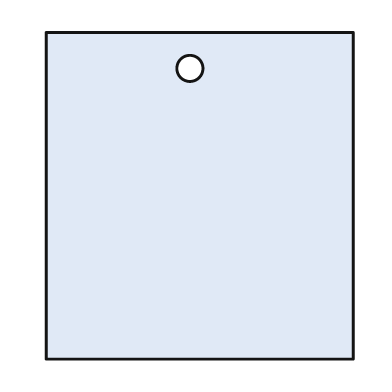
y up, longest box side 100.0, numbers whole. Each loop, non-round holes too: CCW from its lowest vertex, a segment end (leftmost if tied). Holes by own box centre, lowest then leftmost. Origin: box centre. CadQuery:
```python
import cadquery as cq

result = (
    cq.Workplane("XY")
    .moveTo(-47.0, -50.0)
    .lineTo(47.0, -50.0)
    .lineTo(47.0, 50.0)
    .lineTo(-47.0, 50.0)
    .close()
    .moveTo(-3.0, 39.0)
    .circle(4.0)
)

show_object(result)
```